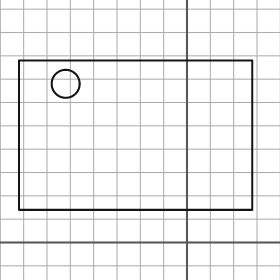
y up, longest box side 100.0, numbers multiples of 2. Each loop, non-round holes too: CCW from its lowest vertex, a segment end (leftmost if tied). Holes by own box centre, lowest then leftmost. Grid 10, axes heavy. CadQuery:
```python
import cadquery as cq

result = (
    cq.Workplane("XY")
    .moveTo(-72.0, 14.0)
    .lineTo(28.0, 14.0)
    .lineTo(28.0, 78.0)
    .lineTo(-72.0, 78.0)
    .close()
    .moveTo(-52.0, 68.0)
    .circle(6.0)
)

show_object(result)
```